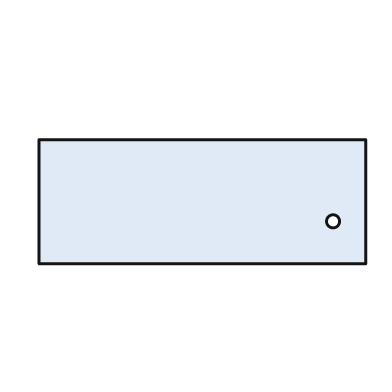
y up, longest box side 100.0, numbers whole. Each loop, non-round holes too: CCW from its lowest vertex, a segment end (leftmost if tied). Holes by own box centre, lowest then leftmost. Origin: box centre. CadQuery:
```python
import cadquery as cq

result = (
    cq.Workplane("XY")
    .moveTo(-50.0, -19.0)
    .lineTo(50.0, -19.0)
    .lineTo(50.0, 19.0)
    .lineTo(-50.0, 19.0)
    .close()
    .moveTo(40.0, -6.0)
    .circle(2.0)
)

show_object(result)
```